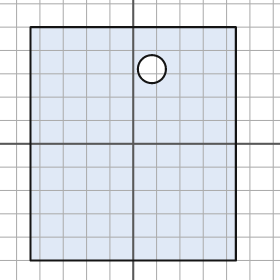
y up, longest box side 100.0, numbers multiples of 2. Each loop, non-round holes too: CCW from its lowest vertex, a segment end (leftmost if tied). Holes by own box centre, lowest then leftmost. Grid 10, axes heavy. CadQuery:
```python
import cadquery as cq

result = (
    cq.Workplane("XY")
    .moveTo(-44.0, -50.0)
    .lineTo(44.0, -50.0)
    .lineTo(44.0, 50.0)
    .lineTo(-44.0, 50.0)
    .close()
    .moveTo(8.0, 32.0)
    .circle(6.0)
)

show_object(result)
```